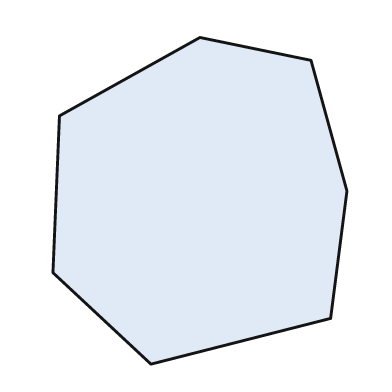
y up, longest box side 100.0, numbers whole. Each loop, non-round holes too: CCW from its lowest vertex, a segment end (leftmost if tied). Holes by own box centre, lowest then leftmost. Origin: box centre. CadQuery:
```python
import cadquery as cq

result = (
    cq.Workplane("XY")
    .moveTo(-15.0, -50.0)
    .lineTo(40.0, -36.0)
    .lineTo(45.0, 3.0)
    .lineTo(34.0, 43.0)
    .lineTo(0.0, 50.0)
    .lineTo(-43.0, 26.0)
    .lineTo(-45.0, -22.0)
    .close()
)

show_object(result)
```